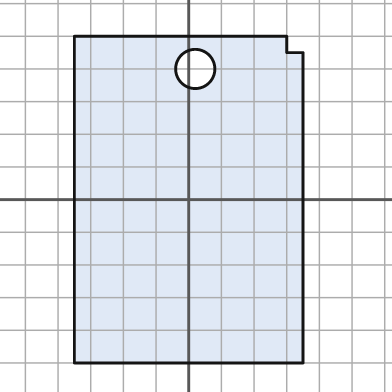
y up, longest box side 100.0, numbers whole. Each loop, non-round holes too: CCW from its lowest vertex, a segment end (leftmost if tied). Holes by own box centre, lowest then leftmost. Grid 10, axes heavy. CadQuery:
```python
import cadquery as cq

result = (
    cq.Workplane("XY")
    .moveTo(-35.0, -50.0)
    .lineTo(35.0, -50.0)
    .lineTo(35.0, 45.0)
    .lineTo(30.0, 45.0)
    .lineTo(30.0, 50.0)
    .lineTo(-35.0, 50.0)
    .close()
    .moveTo(2.0, 40.0)
    .circle(6.0)
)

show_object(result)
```